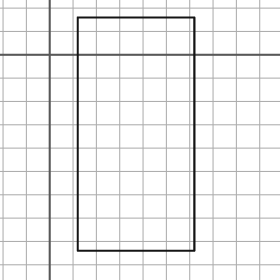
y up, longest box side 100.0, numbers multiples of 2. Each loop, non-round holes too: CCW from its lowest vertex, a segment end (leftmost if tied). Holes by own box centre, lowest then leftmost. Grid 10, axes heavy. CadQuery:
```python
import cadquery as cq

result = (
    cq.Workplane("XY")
    .moveTo(12.0, -84.0)
    .lineTo(62.0, -84.0)
    .lineTo(62.0, 16.0)
    .lineTo(12.0, 16.0)
    .close()
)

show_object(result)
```